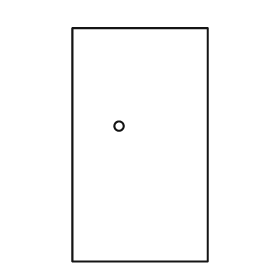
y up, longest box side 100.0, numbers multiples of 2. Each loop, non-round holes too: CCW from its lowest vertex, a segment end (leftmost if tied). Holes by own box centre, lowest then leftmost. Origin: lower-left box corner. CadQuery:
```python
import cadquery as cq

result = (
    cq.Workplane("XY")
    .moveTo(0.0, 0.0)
    .lineTo(58.0, 0.0)
    .lineTo(58.0, 100.0)
    .lineTo(0.0, 100.0)
    .close()
    .moveTo(20.0, 58.0)
    .circle(2.0)
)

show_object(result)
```